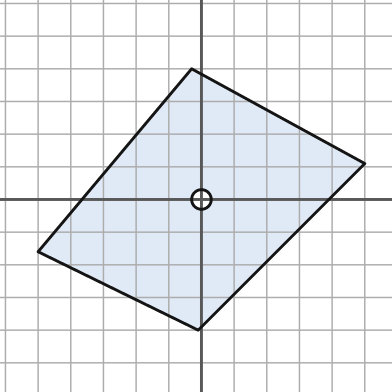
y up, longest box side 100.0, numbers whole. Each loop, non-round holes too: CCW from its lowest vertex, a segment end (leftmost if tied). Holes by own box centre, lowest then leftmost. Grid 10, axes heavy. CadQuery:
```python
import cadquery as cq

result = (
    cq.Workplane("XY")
    .moveTo(-1.0, -40.0)
    .lineTo(50.0, 11.0)
    .lineTo(-3.0, 40.0)
    .lineTo(-50.0, -16.0)
    .close()
    .moveTo(0.0, 0.0)
    .circle(3.0)
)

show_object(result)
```